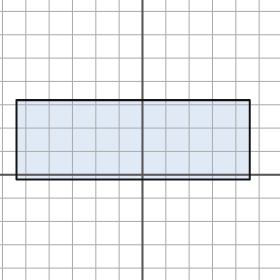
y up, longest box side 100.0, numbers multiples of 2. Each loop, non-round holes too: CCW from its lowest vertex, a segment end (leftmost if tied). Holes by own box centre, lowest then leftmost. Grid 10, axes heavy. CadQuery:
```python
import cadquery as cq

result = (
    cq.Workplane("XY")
    .moveTo(-54.0, -2.0)
    .lineTo(46.0, -2.0)
    .lineTo(46.0, 32.0)
    .lineTo(-54.0, 32.0)
    .close()
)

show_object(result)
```